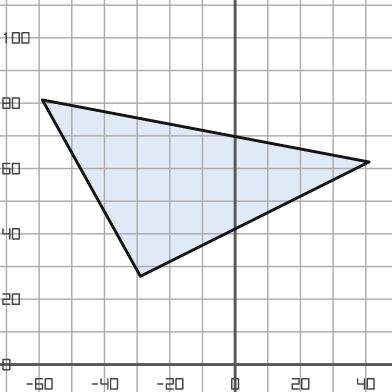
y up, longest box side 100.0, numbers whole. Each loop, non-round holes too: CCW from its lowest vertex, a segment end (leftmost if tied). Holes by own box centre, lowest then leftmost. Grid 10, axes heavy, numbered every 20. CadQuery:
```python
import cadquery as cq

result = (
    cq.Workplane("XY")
    .moveTo(-29.0, 27.0)
    .lineTo(41.0, 62.0)
    .lineTo(-59.0, 81.0)
    .close()
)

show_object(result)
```